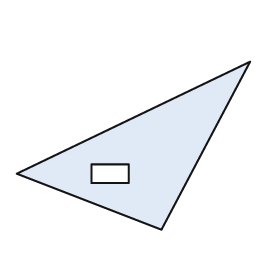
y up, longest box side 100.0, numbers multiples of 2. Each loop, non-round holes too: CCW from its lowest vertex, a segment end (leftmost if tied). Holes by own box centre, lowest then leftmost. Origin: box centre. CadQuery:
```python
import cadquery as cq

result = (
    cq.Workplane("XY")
    .moveTo(12.0, -36.0)
    .lineTo(50.0, 36.0)
    .lineTo(-50.0, -12.0)
    .close()
    .moveTo(-18.0, -16.0)
    .lineTo(-2.0, -16.0)
    .lineTo(-2.0, -8.0)
    .lineTo(-18.0, -8.0)
    .close()
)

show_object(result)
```